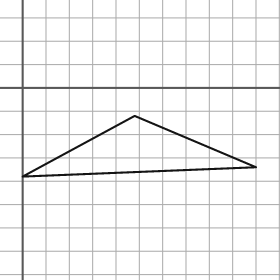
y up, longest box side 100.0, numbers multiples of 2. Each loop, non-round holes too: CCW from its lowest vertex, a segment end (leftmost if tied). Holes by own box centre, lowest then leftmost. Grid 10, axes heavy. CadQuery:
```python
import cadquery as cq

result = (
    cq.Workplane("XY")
    .moveTo(0.0, -38.0)
    .lineTo(100.0, -34.0)
    .lineTo(48.0, -12.0)
    .close()
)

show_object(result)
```